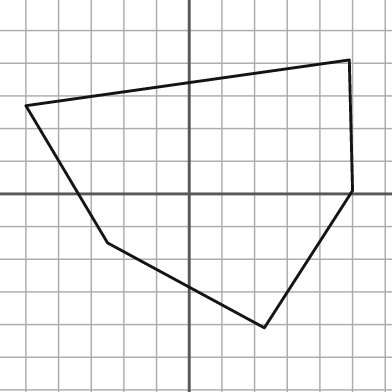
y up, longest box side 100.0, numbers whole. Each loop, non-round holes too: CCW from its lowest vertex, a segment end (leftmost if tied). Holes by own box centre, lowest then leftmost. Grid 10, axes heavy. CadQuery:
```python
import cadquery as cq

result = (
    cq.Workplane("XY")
    .moveTo(23.0, -41.0)
    .lineTo(50.0, 1.0)
    .lineTo(49.0, 41.0)
    .lineTo(-50.0, 27.0)
    .lineTo(-25.0, -15.0)
    .close()
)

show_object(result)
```